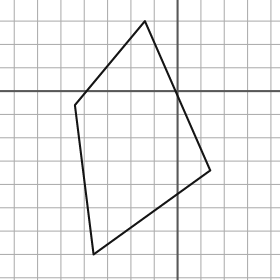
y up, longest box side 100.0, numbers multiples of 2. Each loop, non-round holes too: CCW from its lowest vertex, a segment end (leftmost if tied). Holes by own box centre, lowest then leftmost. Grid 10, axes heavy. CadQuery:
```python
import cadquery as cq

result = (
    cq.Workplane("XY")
    .moveTo(-36.0, -70.0)
    .lineTo(14.0, -34.0)
    .lineTo(-14.0, 30.0)
    .lineTo(-44.0, -6.0)
    .close()
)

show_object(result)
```